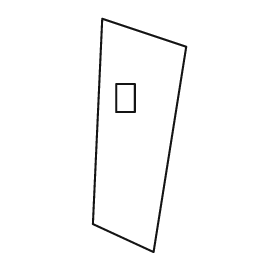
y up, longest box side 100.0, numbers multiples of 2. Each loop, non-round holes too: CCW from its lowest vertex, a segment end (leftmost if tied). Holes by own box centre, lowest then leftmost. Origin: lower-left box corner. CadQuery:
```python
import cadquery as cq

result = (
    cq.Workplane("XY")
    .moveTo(26.0, 0.0)
    .lineTo(40.0, 88.0)
    .lineTo(4.0, 100.0)
    .lineTo(0.0, 12.0)
    .close()
    .moveTo(10.0, 60.0)
    .lineTo(18.0, 60.0)
    .lineTo(18.0, 72.0)
    .lineTo(10.0, 72.0)
    .close()
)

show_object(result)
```